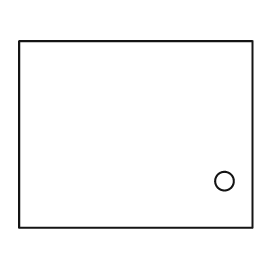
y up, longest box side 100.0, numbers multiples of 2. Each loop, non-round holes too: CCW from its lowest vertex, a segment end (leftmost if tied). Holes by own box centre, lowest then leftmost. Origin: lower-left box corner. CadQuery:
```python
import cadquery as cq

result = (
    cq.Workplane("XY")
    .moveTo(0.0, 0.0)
    .lineTo(100.0, 0.0)
    .lineTo(100.0, 80.0)
    .lineTo(0.0, 80.0)
    .close()
    .moveTo(88.0, 20.0)
    .circle(4.0)
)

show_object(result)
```